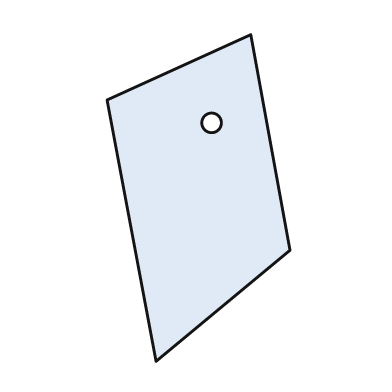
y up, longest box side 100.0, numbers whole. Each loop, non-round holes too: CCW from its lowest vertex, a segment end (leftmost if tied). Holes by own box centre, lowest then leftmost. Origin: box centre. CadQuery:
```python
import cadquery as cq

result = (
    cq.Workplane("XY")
    .moveTo(-13.0, -50.0)
    .lineTo(28.0, -16.0)
    .lineTo(16.0, 50.0)
    .lineTo(-28.0, 30.0)
    .close()
    .moveTo(4.0, 23.0)
    .circle(3.0)
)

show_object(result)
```